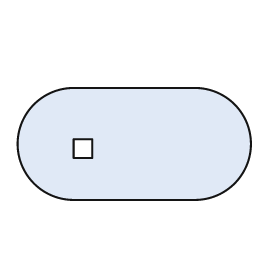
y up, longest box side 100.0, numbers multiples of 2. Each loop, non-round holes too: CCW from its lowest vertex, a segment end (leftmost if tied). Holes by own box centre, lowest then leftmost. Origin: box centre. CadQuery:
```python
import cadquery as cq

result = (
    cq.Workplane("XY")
    .moveTo(-26.0, -24.0)
    .lineTo(26.0, -24.0)
    .threePointArc((50.0, 0.0), (26.0, 24.0))
    .lineTo(-26.0, 24.0)
    .threePointArc((-50.0, 0.0), (-26.0, -24.0))
    .close()
    .moveTo(-26.0, -6.0)
    .lineTo(-18.0, -6.0)
    .lineTo(-18.0, 2.0)
    .lineTo(-26.0, 2.0)
    .close()
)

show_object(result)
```